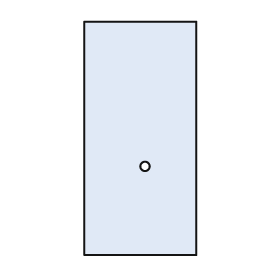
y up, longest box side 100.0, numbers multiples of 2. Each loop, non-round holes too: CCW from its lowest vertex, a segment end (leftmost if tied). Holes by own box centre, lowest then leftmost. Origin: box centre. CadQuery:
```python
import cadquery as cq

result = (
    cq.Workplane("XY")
    .moveTo(-24.0, -50.0)
    .lineTo(24.0, -50.0)
    .lineTo(24.0, 50.0)
    .lineTo(-24.0, 50.0)
    .close()
    .moveTo(2.0, -12.0)
    .circle(2.0)
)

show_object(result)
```